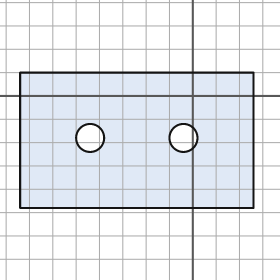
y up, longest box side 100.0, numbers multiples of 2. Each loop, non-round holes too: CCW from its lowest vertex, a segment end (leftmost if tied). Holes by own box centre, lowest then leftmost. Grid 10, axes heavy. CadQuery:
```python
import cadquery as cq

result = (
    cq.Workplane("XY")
    .moveTo(-74.0, -48.0)
    .lineTo(26.0, -48.0)
    .lineTo(26.0, 10.0)
    .lineTo(-74.0, 10.0)
    .close()
    .moveTo(-44.0, -18.0)
    .circle(6.0)
    .moveTo(-4.0, -18.0)
    .circle(6.0)
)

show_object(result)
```